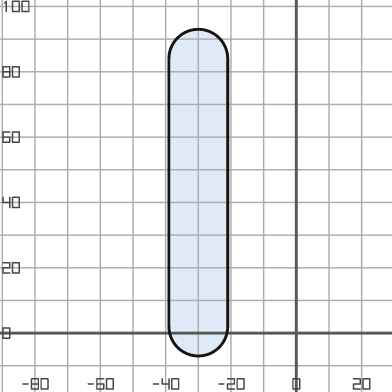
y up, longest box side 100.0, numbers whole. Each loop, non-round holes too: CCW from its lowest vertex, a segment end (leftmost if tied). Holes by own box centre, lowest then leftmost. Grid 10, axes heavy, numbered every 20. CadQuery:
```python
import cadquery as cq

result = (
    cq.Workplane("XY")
    .moveTo(-39.0, 2.0)
    .threePointArc((-30.0, -7.0), (-21.0, 2.0))
    .lineTo(-21.0, 84.0)
    .threePointArc((-30.0, 93.0), (-39.0, 84.0))
    .close()
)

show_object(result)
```